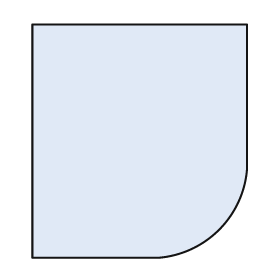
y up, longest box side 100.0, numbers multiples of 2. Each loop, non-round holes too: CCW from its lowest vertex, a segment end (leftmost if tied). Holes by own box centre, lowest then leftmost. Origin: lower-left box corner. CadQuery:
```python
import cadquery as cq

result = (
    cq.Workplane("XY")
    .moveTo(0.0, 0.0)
    .lineTo(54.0, 0.0)
    .threePointArc((80.0, 12.0), (92.0, 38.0))
    .lineTo(92.0, 100.0)
    .lineTo(0.0, 100.0)
    .close()
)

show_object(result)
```